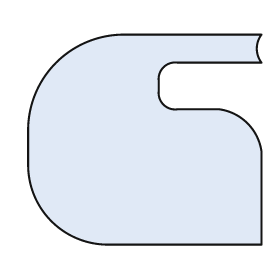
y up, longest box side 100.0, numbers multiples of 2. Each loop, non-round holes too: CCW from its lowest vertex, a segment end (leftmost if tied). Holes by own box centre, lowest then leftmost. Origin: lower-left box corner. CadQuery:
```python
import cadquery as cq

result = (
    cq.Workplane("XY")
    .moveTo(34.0, 0.0)
    .lineTo(100.0, 0.0)
    .lineTo(100.0, 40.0)
    .threePointArc((94.0, 52.0), (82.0, 58.0))
    .lineTo(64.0, 58.0)
    .threePointArc((58.0, 60.0), (56.0, 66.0))
    .lineTo(56.0, 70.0)
    .threePointArc((58.0, 76.0), (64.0, 78.0))
    .lineTo(100.0, 78.0)
    .threePointArc((98.0, 84.0), (100.0, 90.0))
    .lineTo(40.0, 90.0)
    .threePointArc((12.0, 78.0), (0.0, 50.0))
    .lineTo(0.0, 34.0)
    .threePointArc((10.0, 10.0), (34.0, 0.0))
    .close()
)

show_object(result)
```